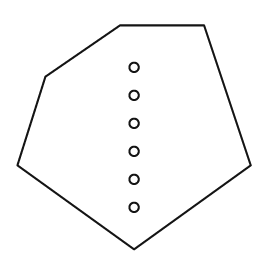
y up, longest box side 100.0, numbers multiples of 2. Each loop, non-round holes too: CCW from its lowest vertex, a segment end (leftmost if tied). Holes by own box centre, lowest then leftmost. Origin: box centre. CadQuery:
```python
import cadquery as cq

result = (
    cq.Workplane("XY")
    .moveTo(0.0, -48.0)
    .lineTo(50.0, -12.0)
    .lineTo(30.0, 48.0)
    .lineTo(-6.0, 48.0)
    .lineTo(-38.0, 26.0)
    .lineTo(-50.0, -12.0)
    .close()
    .moveTo(0.0, -30.0)
    .circle(2.0)
    .moveTo(0.0, -18.0)
    .circle(2.0)
    .moveTo(0.0, -6.0)
    .circle(2.0)
    .moveTo(0.0, 6.0)
    .circle(2.0)
    .moveTo(0.0, 18.0)
    .circle(2.0)
    .moveTo(0.0, 30.0)
    .circle(2.0)
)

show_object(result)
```